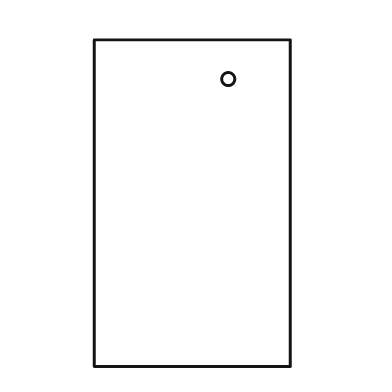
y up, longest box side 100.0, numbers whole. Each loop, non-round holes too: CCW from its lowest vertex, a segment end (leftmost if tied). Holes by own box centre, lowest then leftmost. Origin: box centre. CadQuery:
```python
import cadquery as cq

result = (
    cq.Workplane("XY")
    .moveTo(-30.0, -50.0)
    .lineTo(30.0, -50.0)
    .lineTo(30.0, 50.0)
    .lineTo(-30.0, 50.0)
    .close()
    .moveTo(11.0, 38.0)
    .circle(2.0)
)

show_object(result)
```